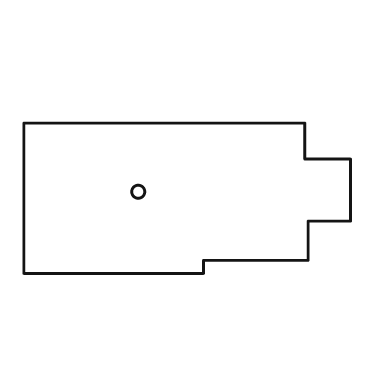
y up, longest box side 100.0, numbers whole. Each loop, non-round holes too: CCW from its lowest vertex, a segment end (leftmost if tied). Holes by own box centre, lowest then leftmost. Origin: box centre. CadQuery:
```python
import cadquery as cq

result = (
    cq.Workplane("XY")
    .moveTo(-50.0, -23.0)
    .lineTo(5.0, -23.0)
    .lineTo(5.0, -19.0)
    .lineTo(37.0, -19.0)
    .lineTo(37.0, -7.0)
    .lineTo(50.0, -7.0)
    .lineTo(50.0, 12.0)
    .lineTo(36.0, 12.0)
    .lineTo(36.0, 23.0)
    .lineTo(-50.0, 23.0)
    .close()
    .moveTo(-15.0, 2.0)
    .circle(2.0)
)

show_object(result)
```